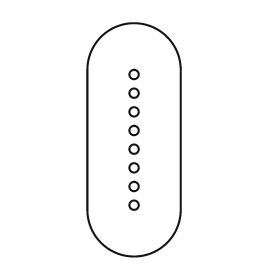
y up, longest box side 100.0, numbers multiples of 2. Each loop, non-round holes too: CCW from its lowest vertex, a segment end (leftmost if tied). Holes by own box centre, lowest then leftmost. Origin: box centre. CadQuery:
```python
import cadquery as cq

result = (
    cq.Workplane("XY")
    .moveTo(-20.0, -30.0)
    .threePointArc((0.0, -50.0), (20.0, -30.0))
    .lineTo(20.0, 30.0)
    .threePointArc((0.0, 50.0), (-20.0, 30.0))
    .close()
    .moveTo(0.0, -28.0)
    .circle(2.0)
    .moveTo(0.0, -20.0)
    .circle(2.0)
    .moveTo(0.0, -12.0)
    .circle(2.0)
    .moveTo(0.0, -4.0)
    .circle(2.0)
    .moveTo(0.0, 4.0)
    .circle(2.0)
    .moveTo(0.0, 12.0)
    .circle(2.0)
    .moveTo(0.0, 20.0)
    .circle(2.0)
    .moveTo(0.0, 28.0)
    .circle(2.0)
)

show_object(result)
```